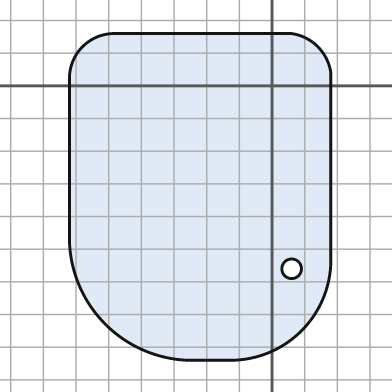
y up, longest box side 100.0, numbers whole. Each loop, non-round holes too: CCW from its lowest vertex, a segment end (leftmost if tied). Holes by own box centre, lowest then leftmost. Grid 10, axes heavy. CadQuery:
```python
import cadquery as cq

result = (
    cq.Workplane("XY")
    .moveTo(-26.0, -84.0)
    .lineTo(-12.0, -84.0)
    .threePointArc((9.0, -75.0), (18.0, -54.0))
    .lineTo(18.0, 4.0)
    .threePointArc((14.0, 12.0), (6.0, 16.0))
    .lineTo(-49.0, 16.0)
    .threePointArc((-58.0, 12.0), (-62.0, 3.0))
    .lineTo(-62.0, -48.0)
    .threePointArc((-51.0, -73.0), (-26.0, -84.0))
    .close()
    .moveTo(6.0, -56.0)
    .circle(3.0)
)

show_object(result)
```